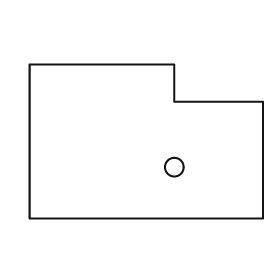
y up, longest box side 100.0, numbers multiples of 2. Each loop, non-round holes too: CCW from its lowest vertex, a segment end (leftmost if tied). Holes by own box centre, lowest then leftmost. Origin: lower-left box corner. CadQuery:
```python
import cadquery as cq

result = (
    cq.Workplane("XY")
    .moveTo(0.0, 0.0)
    .lineTo(100.0, 0.0)
    .lineTo(100.0, 50.0)
    .lineTo(62.0, 50.0)
    .lineTo(62.0, 66.0)
    .lineTo(0.0, 66.0)
    .close()
    .moveTo(62.0, 22.0)
    .circle(4.0)
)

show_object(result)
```